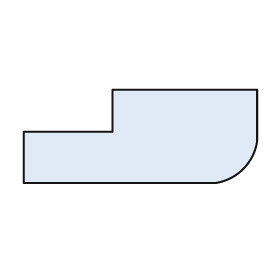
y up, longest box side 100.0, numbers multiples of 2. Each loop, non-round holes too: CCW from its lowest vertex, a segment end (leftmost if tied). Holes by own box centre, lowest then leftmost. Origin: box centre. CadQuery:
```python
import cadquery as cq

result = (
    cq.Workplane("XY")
    .moveTo(-50.0, -20.0)
    .lineTo(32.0, -20.0)
    .threePointArc((44.0, -14.0), (50.0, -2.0))
    .lineTo(50.0, 20.0)
    .lineTo(-12.0, 20.0)
    .lineTo(-12.0, 2.0)
    .lineTo(-50.0, 2.0)
    .close()
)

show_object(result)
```